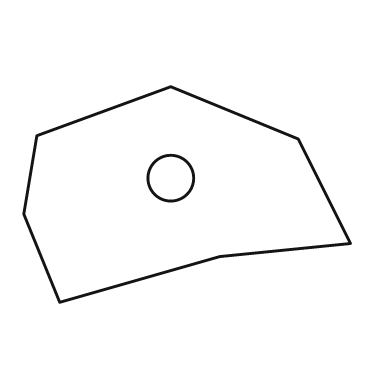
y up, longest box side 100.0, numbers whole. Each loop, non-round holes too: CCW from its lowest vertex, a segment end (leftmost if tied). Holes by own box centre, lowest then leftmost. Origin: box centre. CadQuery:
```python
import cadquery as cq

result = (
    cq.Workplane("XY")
    .moveTo(-39.0, -33.0)
    .lineTo(10.0, -19.0)
    .lineTo(50.0, -15.0)
    .lineTo(34.0, 17.0)
    .lineTo(-5.0, 33.0)
    .lineTo(-46.0, 18.0)
    .lineTo(-50.0, -6.0)
    .close()
    .moveTo(-5.0, 5.0)
    .circle(7.0)
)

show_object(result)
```